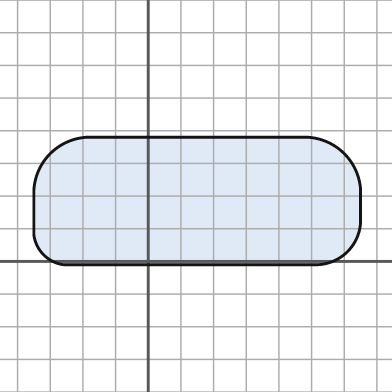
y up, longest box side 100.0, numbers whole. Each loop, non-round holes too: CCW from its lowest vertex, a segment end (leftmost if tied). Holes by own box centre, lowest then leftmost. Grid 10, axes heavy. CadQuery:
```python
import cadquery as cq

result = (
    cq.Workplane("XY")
    .moveTo(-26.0, -1.0)
    .lineTo(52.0, -1.0)
    .threePointArc((61.0, 3.0), (65.0, 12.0))
    .lineTo(65.0, 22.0)
    .threePointArc((60.0, 33.0), (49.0, 38.0))
    .lineTo(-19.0, 38.0)
    .threePointArc((-30.0, 33.0), (-35.0, 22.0))
    .lineTo(-35.0, 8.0)
    .threePointArc((-32.0, 2.0), (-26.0, -1.0))
    .close()
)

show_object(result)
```